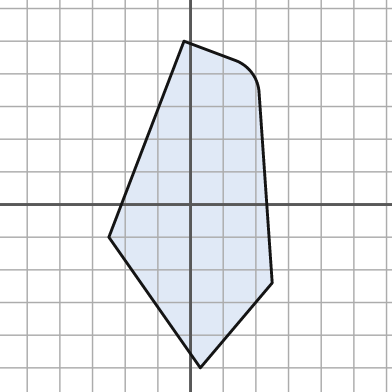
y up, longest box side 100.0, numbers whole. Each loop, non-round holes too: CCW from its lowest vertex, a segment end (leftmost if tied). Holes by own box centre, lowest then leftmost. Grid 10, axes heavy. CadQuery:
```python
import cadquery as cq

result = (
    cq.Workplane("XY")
    .moveTo(3.0, -50.0)
    .lineTo(25.0, -24.0)
    .lineTo(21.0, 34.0)
    .threePointArc((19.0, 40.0), (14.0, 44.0))
    .lineTo(-2.0, 50.0)
    .lineTo(-25.0, -10.0)
    .close()
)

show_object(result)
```